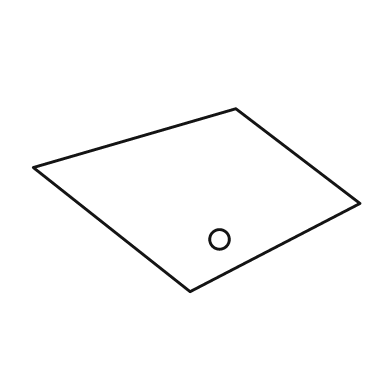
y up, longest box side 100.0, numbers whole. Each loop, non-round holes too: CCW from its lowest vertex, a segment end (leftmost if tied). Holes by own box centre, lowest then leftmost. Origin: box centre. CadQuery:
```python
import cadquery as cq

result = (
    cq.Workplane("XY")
    .moveTo(-2.0, -28.0)
    .lineTo(50.0, -1.0)
    .lineTo(12.0, 28.0)
    .lineTo(-50.0, 10.0)
    .close()
    .moveTo(7.0, -12.0)
    .circle(3.0)
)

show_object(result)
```